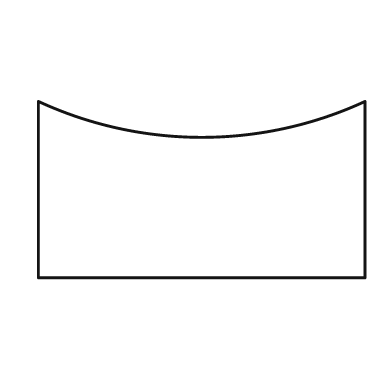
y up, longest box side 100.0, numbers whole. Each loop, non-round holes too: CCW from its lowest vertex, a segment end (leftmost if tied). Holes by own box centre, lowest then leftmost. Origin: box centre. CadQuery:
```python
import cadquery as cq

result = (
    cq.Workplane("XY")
    .moveTo(-50.0, -27.0)
    .lineTo(50.0, -27.0)
    .lineTo(50.0, 27.0)
    .threePointArc((0.0, 16.0), (-50.0, 27.0))
    .close()
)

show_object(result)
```